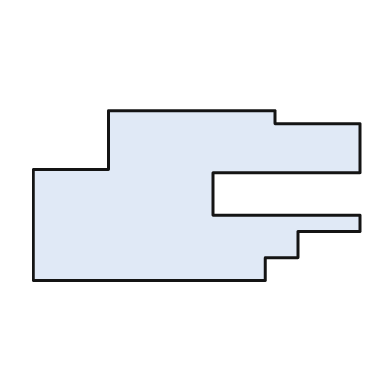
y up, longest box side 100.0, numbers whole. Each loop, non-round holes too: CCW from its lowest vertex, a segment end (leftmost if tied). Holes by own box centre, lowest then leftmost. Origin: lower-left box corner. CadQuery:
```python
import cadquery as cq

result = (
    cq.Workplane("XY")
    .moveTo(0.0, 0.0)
    .lineTo(71.0, 0.0)
    .lineTo(71.0, 7.0)
    .lineTo(81.0, 7.0)
    .lineTo(81.0, 15.0)
    .lineTo(100.0, 15.0)
    .lineTo(100.0, 20.0)
    .lineTo(55.0, 20.0)
    .lineTo(55.0, 33.0)
    .lineTo(100.0, 33.0)
    .lineTo(100.0, 48.0)
    .lineTo(74.0, 48.0)
    .lineTo(74.0, 52.0)
    .lineTo(23.0, 52.0)
    .lineTo(23.0, 34.0)
    .lineTo(0.0, 34.0)
    .close()
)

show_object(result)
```